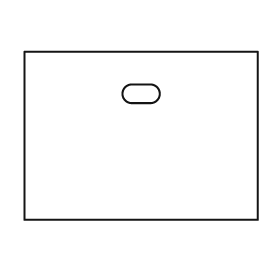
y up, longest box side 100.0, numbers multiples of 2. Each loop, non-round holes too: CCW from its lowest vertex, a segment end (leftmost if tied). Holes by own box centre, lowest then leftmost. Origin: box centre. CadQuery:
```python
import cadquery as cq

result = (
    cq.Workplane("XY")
    .moveTo(-50.0, -36.0)
    .lineTo(50.0, -36.0)
    .lineTo(50.0, 36.0)
    .lineTo(-50.0, 36.0)
    .close()
    .moveTo(-4.0, 14.0)
    .lineTo(4.0, 14.0)
    .threePointArc((8.0, 18.0), (4.0, 22.0))
    .lineTo(-4.0, 22.0)
    .threePointArc((-8.0, 18.0), (-4.0, 14.0))
    .close()
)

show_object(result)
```